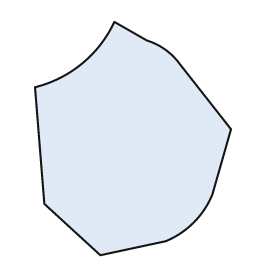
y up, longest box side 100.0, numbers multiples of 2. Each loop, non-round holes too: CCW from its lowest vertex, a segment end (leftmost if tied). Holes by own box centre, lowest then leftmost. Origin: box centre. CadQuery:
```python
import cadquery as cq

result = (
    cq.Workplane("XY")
    .moveTo(-14.0, -50.0)
    .lineTo(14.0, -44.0)
    .threePointArc((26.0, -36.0), (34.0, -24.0))
    .lineTo(42.0, 4.0)
    .lineTo(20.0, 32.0)
    .threePointArc((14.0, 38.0), (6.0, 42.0))
    .lineTo(-8.0, 50.0)
    .threePointArc((-22.0, 32.0), (-42.0, 22.0))
    .lineTo(-38.0, -28.0)
    .close()
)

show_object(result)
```